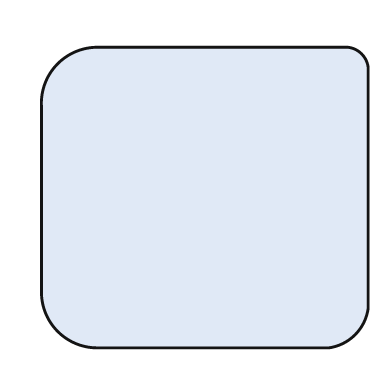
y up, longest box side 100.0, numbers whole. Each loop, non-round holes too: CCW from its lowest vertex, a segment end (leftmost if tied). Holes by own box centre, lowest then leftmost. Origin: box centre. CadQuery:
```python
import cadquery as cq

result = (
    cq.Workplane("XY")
    .moveTo(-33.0, -46.0)
    .lineTo(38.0, -46.0)
    .threePointArc((46.0, -42.0), (50.0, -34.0))
    .lineTo(50.0, 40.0)
    .threePointArc((48.0, 44.0), (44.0, 46.0))
    .lineTo(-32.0, 46.0)
    .threePointArc((-45.0, 41.0), (-50.0, 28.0))
    .lineTo(-50.0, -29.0)
    .threePointArc((-45.0, -41.0), (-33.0, -46.0))
    .close()
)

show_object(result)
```